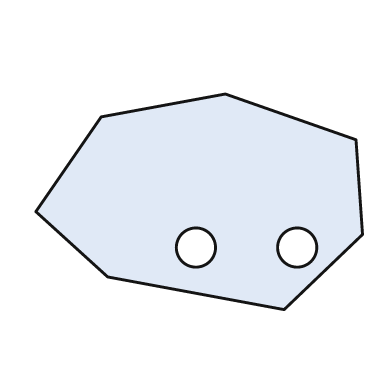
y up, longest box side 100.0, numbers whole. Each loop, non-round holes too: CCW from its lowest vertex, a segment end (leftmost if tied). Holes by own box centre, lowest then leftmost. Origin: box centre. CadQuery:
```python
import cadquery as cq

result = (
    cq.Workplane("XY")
    .moveTo(26.0, -33.0)
    .lineTo(50.0, -10.0)
    .lineTo(48.0, 19.0)
    .lineTo(8.0, 33.0)
    .lineTo(-30.0, 26.0)
    .lineTo(-50.0, -3.0)
    .lineTo(-28.0, -23.0)
    .close()
    .moveTo(-1.0, -14.0)
    .circle(6.0)
    .moveTo(30.0, -14.0)
    .circle(6.0)
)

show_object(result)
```